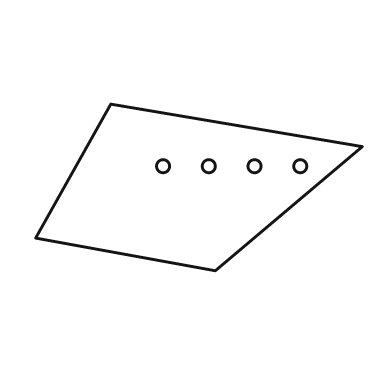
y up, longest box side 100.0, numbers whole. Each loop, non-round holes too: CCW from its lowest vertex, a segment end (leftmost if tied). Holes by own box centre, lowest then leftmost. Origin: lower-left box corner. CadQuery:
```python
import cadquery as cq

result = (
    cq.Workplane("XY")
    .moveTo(55.0, 0.0)
    .lineTo(100.0, 38.0)
    .lineTo(23.0, 51.0)
    .lineTo(0.0, 10.0)
    .close()
    .moveTo(39.0, 32.0)
    .circle(2.0)
    .moveTo(53.0, 32.0)
    .circle(2.0)
    .moveTo(67.0, 32.0)
    .circle(2.0)
    .moveTo(81.0, 32.0)
    .circle(2.0)
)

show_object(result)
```